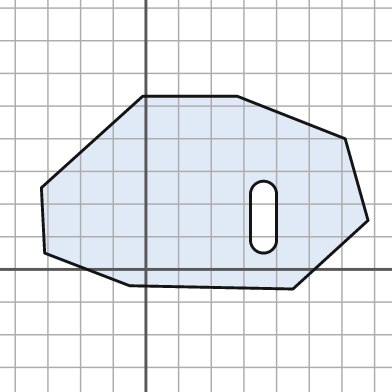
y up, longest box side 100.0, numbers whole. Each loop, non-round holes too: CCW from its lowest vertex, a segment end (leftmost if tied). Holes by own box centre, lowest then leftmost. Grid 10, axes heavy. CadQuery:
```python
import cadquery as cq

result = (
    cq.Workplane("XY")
    .moveTo(45.0, -6.0)
    .lineTo(68.0, 15.0)
    .lineTo(61.0, 40.0)
    .lineTo(28.0, 53.0)
    .lineTo(-1.0, 53.0)
    .lineTo(-32.0, 25.0)
    .lineTo(-31.0, 5.0)
    .lineTo(-5.0, -5.0)
    .close()
    .moveTo(32.0, 9.0)
    .threePointArc((36.0, 5.0), (40.0, 9.0))
    .lineTo(40.0, 23.0)
    .threePointArc((36.0, 27.0), (32.0, 23.0))
    .close()
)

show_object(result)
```